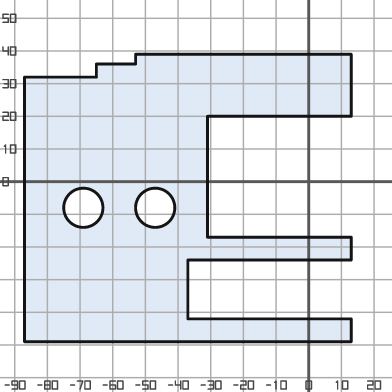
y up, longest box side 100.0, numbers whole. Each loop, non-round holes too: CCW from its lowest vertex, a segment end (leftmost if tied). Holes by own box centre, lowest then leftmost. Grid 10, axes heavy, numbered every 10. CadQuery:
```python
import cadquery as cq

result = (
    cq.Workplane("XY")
    .moveTo(-87.0, -49.0)
    .lineTo(13.0, -49.0)
    .lineTo(13.0, -42.0)
    .lineTo(-37.0, -42.0)
    .lineTo(-37.0, -24.0)
    .lineTo(13.0, -24.0)
    .lineTo(13.0, -17.0)
    .lineTo(-31.0, -17.0)
    .lineTo(-31.0, 20.0)
    .lineTo(13.0, 20.0)
    .lineTo(13.0, 39.0)
    .lineTo(-53.0, 39.0)
    .lineTo(-53.0, 36.0)
    .lineTo(-65.0, 36.0)
    .lineTo(-65.0, 32.0)
    .lineTo(-87.0, 32.0)
    .close()
    .moveTo(-69.0, -8.0)
    .circle(6.0)
    .moveTo(-47.0, -8.0)
    .circle(6.0)
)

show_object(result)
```